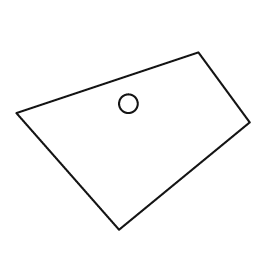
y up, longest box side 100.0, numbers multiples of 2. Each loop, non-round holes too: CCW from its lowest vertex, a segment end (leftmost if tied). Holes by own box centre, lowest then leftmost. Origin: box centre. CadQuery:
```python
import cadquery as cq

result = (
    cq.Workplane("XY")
    .moveTo(-6.0, -38.0)
    .lineTo(50.0, 8.0)
    .lineTo(28.0, 38.0)
    .lineTo(-50.0, 12.0)
    .close()
    .moveTo(-2.0, 16.0)
    .circle(4.0)
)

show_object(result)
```